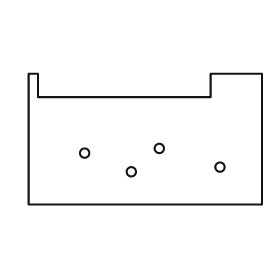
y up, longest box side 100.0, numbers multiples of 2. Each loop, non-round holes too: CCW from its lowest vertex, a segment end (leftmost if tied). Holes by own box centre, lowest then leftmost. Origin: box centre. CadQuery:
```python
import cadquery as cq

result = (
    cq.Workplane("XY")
    .moveTo(-50.0, -28.0)
    .lineTo(50.0, -28.0)
    .lineTo(50.0, 28.0)
    .lineTo(28.0, 28.0)
    .lineTo(28.0, 18.0)
    .lineTo(-46.0, 18.0)
    .lineTo(-46.0, 28.0)
    .lineTo(-50.0, 28.0)
    .close()
    .moveTo(-6.0, -14.0)
    .circle(2.0)
    .moveTo(32.0, -12.0)
    .circle(2.0)
    .moveTo(-26.0, -6.0)
    .circle(2.0)
    .moveTo(6.0, -4.0)
    .circle(2.0)
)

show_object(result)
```